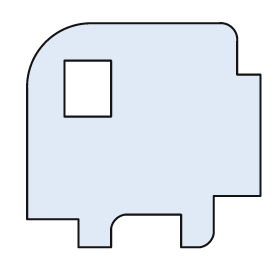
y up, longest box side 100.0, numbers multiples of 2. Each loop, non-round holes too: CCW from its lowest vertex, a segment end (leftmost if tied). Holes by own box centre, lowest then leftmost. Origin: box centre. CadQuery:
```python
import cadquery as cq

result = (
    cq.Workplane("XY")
    .moveTo(-28.0, -48.0)
    .lineTo(-14.0, -48.0)
    .lineTo(-14.0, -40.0)
    .threePointArc((-12.0, -36.0), (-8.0, -34.0))
    .lineTo(16.0, -34.0)
    .lineTo(16.0, -48.0)
    .lineTo(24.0, -48.0)
    .threePointArc((28.0, -46.0), (30.0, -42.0))
    .lineTo(30.0, -26.0)
    .lineTo(50.0, -26.0)
    .lineTo(50.0, 26.0)
    .lineTo(40.0, 26.0)
    .lineTo(40.0, 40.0)
    .threePointArc((38.0, 46.0), (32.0, 48.0))
    .lineTo(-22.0, 48.0)
    .threePointArc((-42.0, 40.0), (-50.0, 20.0))
    .lineTo(-50.0, -36.0)
    .lineTo(-28.0, -36.0)
    .close()
    .moveTo(-34.0, 8.0)
    .lineTo(-14.0, 8.0)
    .lineTo(-14.0, 32.0)
    .lineTo(-34.0, 32.0)
    .close()
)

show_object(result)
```